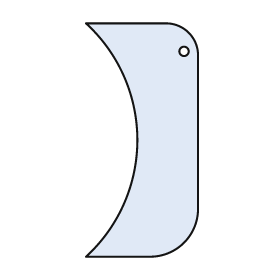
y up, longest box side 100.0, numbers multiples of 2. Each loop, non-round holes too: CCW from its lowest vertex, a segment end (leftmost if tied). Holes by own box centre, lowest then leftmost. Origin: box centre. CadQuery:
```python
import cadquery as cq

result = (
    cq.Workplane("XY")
    .moveTo(-24.0, -50.0)
    .lineTo(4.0, -50.0)
    .threePointArc((18.0, -44.0), (24.0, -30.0))
    .lineTo(24.0, 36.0)
    .threePointArc((20.0, 46.0), (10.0, 50.0))
    .lineTo(-24.0, 50.0)
    .threePointArc((-2.0, 0.0), (-24.0, -50.0))
    .close()
    .moveTo(18.0, 38.0)
    .circle(2.0)
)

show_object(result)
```